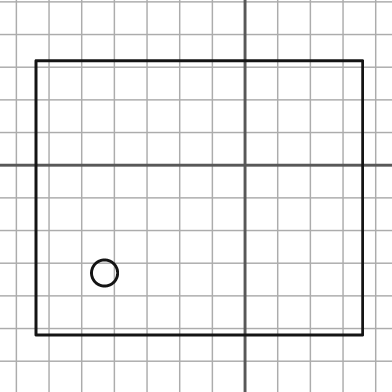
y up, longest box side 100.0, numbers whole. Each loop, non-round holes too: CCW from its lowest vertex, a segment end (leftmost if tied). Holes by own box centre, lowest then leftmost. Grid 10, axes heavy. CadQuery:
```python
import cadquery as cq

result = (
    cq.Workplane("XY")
    .moveTo(-64.0, -52.0)
    .lineTo(36.0, -52.0)
    .lineTo(36.0, 32.0)
    .lineTo(-64.0, 32.0)
    .close()
    .moveTo(-43.0, -33.0)
    .circle(4.0)
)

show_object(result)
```